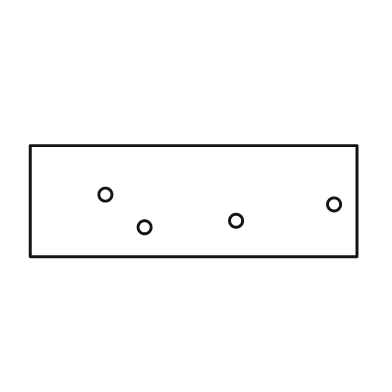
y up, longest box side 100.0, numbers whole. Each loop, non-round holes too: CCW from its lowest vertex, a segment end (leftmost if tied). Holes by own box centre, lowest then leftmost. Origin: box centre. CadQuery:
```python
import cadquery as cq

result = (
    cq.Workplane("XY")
    .moveTo(-50.0, -17.0)
    .lineTo(50.0, -17.0)
    .lineTo(50.0, 17.0)
    .lineTo(-50.0, 17.0)
    .close()
    .moveTo(-15.0, -8.0)
    .circle(2.0)
    .moveTo(13.0, -6.0)
    .circle(2.0)
    .moveTo(43.0, -1.0)
    .circle(2.0)
    .moveTo(-27.0, 2.0)
    .circle(2.0)
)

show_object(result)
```